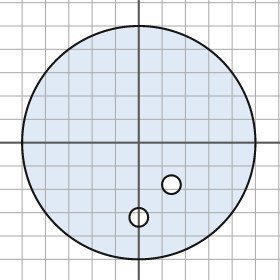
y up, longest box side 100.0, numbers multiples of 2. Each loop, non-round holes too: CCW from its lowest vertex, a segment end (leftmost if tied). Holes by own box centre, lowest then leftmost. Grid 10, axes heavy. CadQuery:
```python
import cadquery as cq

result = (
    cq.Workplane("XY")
    .moveTo(0.0, 0.0)
    .circle(50.0)
    .moveTo(0.0, -32.0)
    .circle(4.0)
    .moveTo(14.0, -18.0)
    .circle(4.0)
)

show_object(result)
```